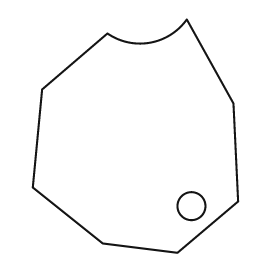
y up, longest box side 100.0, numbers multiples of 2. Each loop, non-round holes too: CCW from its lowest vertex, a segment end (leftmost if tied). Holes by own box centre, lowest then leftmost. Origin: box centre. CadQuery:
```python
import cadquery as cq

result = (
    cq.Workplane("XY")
    .moveTo(18.0, -50.0)
    .lineTo(44.0, -28.0)
    .lineTo(42.0, 14.0)
    .lineTo(22.0, 50.0)
    .threePointArc((6.0, 40.0), (-12.0, 44.0))
    .lineTo(-40.0, 20.0)
    .lineTo(-44.0, -22.0)
    .lineTo(-14.0, -46.0)
    .close()
    .moveTo(24.0, -30.0)
    .circle(6.0)
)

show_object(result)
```